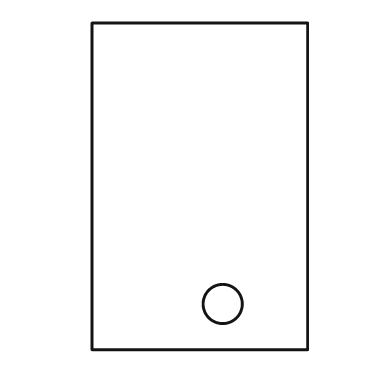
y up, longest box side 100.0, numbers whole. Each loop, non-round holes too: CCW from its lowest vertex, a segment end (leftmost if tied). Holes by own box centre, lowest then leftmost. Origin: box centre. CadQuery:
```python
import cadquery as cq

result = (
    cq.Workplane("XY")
    .moveTo(-33.0, -50.0)
    .lineTo(33.0, -50.0)
    .lineTo(33.0, 50.0)
    .lineTo(-33.0, 50.0)
    .close()
    .moveTo(7.0, -36.0)
    .circle(6.0)
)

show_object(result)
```